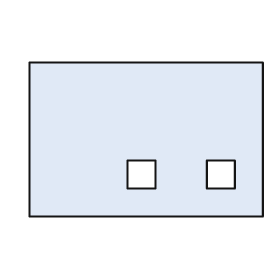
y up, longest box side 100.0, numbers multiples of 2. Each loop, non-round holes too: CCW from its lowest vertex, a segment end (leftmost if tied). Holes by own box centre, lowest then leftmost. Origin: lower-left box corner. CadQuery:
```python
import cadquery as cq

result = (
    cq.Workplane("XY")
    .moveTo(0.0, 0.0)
    .lineTo(100.0, 0.0)
    .lineTo(100.0, 66.0)
    .lineTo(0.0, 66.0)
    .close()
    .moveTo(42.0, 12.0)
    .lineTo(54.0, 12.0)
    .lineTo(54.0, 24.0)
    .lineTo(42.0, 24.0)
    .close()
    .moveTo(76.0, 12.0)
    .lineTo(88.0, 12.0)
    .lineTo(88.0, 24.0)
    .lineTo(76.0, 24.0)
    .close()
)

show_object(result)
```